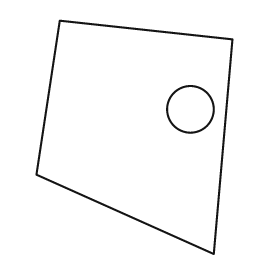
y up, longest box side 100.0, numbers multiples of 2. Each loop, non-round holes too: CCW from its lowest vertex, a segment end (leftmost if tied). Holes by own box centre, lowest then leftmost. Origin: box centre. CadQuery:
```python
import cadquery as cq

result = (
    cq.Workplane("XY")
    .moveTo(34.0, -50.0)
    .lineTo(42.0, 42.0)
    .lineTo(-32.0, 50.0)
    .lineTo(-42.0, -16.0)
    .close()
    .moveTo(24.0, 12.0)
    .circle(10.0)
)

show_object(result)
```